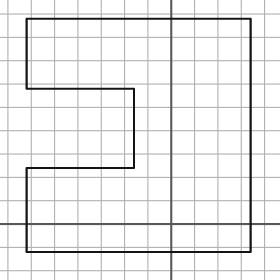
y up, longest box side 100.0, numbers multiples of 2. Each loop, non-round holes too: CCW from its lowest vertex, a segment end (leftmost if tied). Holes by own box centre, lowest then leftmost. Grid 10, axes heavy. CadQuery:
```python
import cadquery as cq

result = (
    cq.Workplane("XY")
    .moveTo(-62.0, -12.0)
    .lineTo(34.0, -12.0)
    .lineTo(34.0, 88.0)
    .lineTo(-62.0, 88.0)
    .lineTo(-62.0, 58.0)
    .lineTo(-16.0, 58.0)
    .lineTo(-16.0, 24.0)
    .lineTo(-62.0, 24.0)
    .close()
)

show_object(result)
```